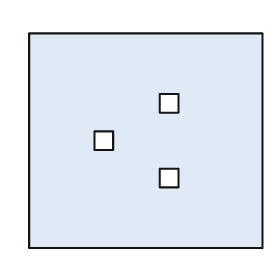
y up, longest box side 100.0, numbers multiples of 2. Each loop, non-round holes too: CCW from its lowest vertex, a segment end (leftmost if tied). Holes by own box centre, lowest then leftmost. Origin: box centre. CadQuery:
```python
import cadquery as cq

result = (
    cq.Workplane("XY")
    .moveTo(-50.0, -46.0)
    .lineTo(50.0, -46.0)
    .lineTo(50.0, 46.0)
    .lineTo(-50.0, 46.0)
    .close()
    .moveTo(6.0, -20.0)
    .lineTo(14.0, -20.0)
    .lineTo(14.0, -12.0)
    .lineTo(6.0, -12.0)
    .close()
    .moveTo(-22.0, -4.0)
    .lineTo(-14.0, -4.0)
    .lineTo(-14.0, 4.0)
    .lineTo(-22.0, 4.0)
    .close()
    .moveTo(6.0, 12.0)
    .lineTo(14.0, 12.0)
    .lineTo(14.0, 20.0)
    .lineTo(6.0, 20.0)
    .close()
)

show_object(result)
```